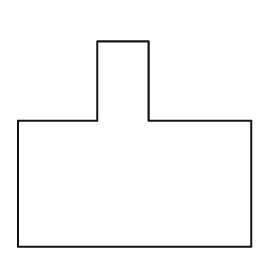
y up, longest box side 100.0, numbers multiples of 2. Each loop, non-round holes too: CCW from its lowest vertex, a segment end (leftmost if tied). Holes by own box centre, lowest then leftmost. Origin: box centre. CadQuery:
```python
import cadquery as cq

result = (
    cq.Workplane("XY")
    .moveTo(-50.0, -44.0)
    .lineTo(50.0, -44.0)
    .lineTo(50.0, 10.0)
    .lineTo(6.0, 10.0)
    .lineTo(6.0, 44.0)
    .lineTo(-16.0, 44.0)
    .lineTo(-16.0, 10.0)
    .lineTo(-50.0, 10.0)
    .close()
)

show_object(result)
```